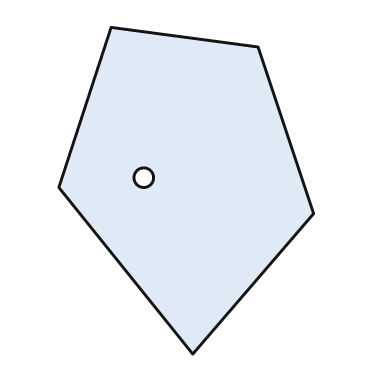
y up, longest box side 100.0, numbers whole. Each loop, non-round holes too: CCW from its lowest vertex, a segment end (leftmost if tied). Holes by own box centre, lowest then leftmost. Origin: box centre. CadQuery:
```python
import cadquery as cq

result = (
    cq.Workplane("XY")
    .moveTo(2.0, -50.0)
    .lineTo(39.0, -7.0)
    .lineTo(22.0, 44.0)
    .lineTo(-23.0, 50.0)
    .lineTo(-39.0, 1.0)
    .close()
    .moveTo(-13.0, 4.0)
    .circle(3.0)
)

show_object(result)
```